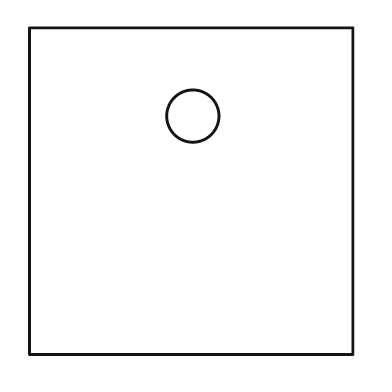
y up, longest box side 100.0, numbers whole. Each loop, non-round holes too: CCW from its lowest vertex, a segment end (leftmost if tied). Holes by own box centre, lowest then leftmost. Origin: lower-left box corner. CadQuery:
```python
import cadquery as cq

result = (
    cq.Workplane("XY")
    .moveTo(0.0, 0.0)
    .lineTo(99.0, 0.0)
    .lineTo(99.0, 100.0)
    .lineTo(0.0, 100.0)
    .close()
    .moveTo(50.0, 73.0)
    .circle(8.0)
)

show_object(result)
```